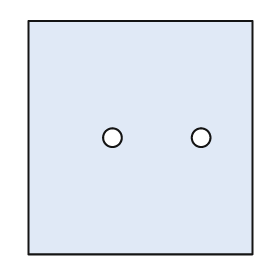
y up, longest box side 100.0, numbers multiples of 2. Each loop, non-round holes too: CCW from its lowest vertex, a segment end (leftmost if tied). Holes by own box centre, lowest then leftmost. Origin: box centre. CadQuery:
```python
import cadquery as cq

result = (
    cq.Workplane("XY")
    .moveTo(-48.0, -50.0)
    .lineTo(48.0, -50.0)
    .lineTo(48.0, 50.0)
    .lineTo(-48.0, 50.0)
    .close()
    .moveTo(-12.0, 0.0)
    .circle(4.0)
    .moveTo(26.0, 0.0)
    .circle(4.0)
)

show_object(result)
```